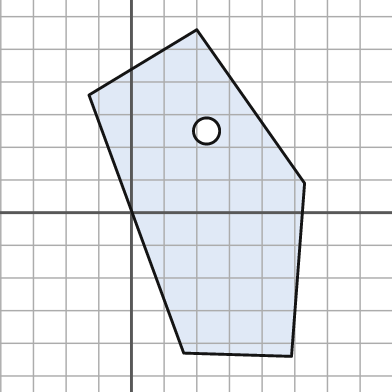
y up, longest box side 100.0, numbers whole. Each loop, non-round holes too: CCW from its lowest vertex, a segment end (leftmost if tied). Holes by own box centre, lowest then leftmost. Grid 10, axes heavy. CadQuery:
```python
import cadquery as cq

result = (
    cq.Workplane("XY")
    .moveTo(49.0, -44.0)
    .lineTo(53.0, 9.0)
    .lineTo(20.0, 56.0)
    .lineTo(-13.0, 36.0)
    .lineTo(16.0, -43.0)
    .close()
    .moveTo(23.0, 25.0)
    .circle(4.0)
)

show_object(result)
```